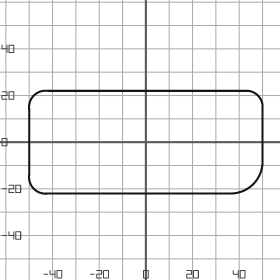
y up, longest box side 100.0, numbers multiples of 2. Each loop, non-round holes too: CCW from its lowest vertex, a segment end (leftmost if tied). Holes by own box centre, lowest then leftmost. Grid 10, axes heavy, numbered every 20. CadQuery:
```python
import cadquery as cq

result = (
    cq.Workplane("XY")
    .moveTo(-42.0, -22.0)
    .lineTo(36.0, -22.0)
    .threePointArc((46.0, -18.0), (50.0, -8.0))
    .lineTo(50.0, 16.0)
    .threePointArc((48.0, 20.0), (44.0, 22.0))
    .lineTo(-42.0, 22.0)
    .threePointArc((-48.0, 20.0), (-50.0, 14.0))
    .lineTo(-50.0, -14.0)
    .threePointArc((-48.0, -20.0), (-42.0, -22.0))
    .close()
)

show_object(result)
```